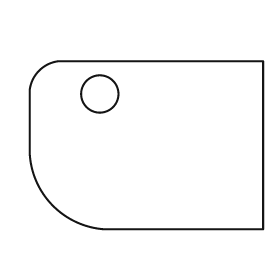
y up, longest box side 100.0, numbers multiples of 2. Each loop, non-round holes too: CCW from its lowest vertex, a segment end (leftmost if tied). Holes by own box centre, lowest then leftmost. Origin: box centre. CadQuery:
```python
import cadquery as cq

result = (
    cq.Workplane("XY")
    .moveTo(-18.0, -36.0)
    .lineTo(50.0, -36.0)
    .lineTo(50.0, 36.0)
    .lineTo(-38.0, 36.0)
    .threePointArc((-46.0, 32.0), (-50.0, 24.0))
    .lineTo(-50.0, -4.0)
    .threePointArc((-40.0, -26.0), (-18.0, -36.0))
    .close()
    .moveTo(-20.0, 22.0)
    .circle(8.0)
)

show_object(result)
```